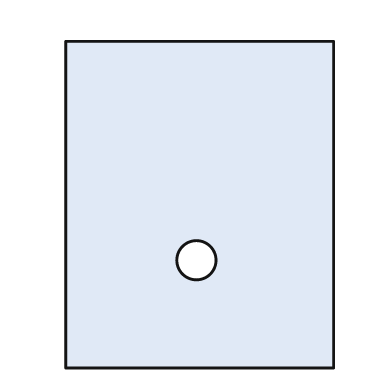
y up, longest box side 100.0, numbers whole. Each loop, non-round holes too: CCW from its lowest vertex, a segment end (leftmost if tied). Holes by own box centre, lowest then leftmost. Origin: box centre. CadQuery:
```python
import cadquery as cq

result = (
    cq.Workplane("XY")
    .moveTo(-41.0, -50.0)
    .lineTo(41.0, -50.0)
    .lineTo(41.0, 50.0)
    .lineTo(-41.0, 50.0)
    .close()
    .moveTo(-1.0, -17.0)
    .circle(6.0)
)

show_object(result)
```